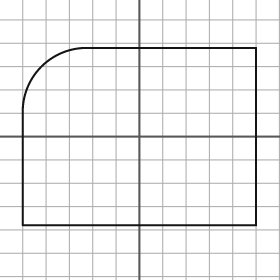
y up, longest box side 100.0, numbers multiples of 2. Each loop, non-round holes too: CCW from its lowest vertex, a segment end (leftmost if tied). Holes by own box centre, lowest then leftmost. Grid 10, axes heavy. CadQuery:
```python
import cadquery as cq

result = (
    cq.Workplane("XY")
    .moveTo(-50.0, -38.0)
    .lineTo(50.0, -38.0)
    .lineTo(50.0, 38.0)
    .lineTo(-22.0, 38.0)
    .threePointArc((-42.0, 30.0), (-50.0, 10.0))
    .close()
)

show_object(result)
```